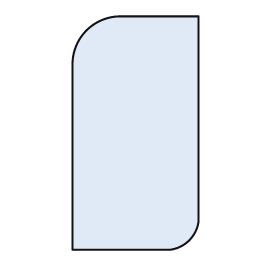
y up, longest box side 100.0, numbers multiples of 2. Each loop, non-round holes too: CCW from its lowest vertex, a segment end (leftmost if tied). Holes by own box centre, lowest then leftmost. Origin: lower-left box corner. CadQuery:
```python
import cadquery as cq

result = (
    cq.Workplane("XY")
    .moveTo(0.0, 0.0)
    .lineTo(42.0, 0.0)
    .threePointArc((50.0, 4.0), (54.0, 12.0))
    .lineTo(54.0, 100.0)
    .lineTo(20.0, 100.0)
    .threePointArc((6.0, 94.0), (0.0, 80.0))
    .close()
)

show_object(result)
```